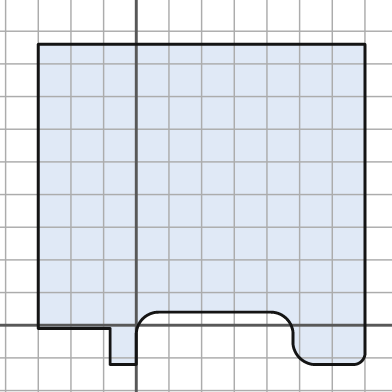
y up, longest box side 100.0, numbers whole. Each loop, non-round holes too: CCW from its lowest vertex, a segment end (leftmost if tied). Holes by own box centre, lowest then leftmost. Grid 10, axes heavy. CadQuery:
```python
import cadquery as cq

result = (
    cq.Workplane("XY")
    .moveTo(-8.0, -12.0)
    .lineTo(0.0, -12.0)
    .lineTo(0.0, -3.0)
    .threePointArc((2.0, 2.0), (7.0, 4.0))
    .lineTo(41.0, 4.0)
    .threePointArc((46.0, 2.0), (48.0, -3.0))
    .lineTo(48.0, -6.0)
    .threePointArc((50.0, -10.0), (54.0, -12.0))
    .lineTo(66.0, -12.0)
    .threePointArc((69.0, -11.0), (70.0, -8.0))
    .lineTo(70.0, 86.0)
    .lineTo(-30.0, 86.0)
    .lineTo(-30.0, -1.0)
    .lineTo(-8.0, -1.0)
    .close()
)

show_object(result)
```